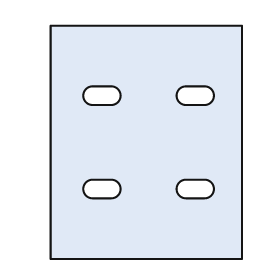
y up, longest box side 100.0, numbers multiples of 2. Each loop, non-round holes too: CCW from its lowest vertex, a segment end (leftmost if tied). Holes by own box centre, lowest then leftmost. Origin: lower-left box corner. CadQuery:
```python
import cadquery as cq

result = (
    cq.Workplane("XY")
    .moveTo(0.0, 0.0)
    .lineTo(82.0, 0.0)
    .lineTo(82.0, 100.0)
    .lineTo(0.0, 100.0)
    .close()
    .moveTo(18.0, 26.0)
    .lineTo(26.0, 26.0)
    .threePointArc((30.0, 30.0), (26.0, 34.0))
    .lineTo(18.0, 34.0)
    .threePointArc((14.0, 30.0), (18.0, 26.0))
    .close()
    .moveTo(58.0, 26.0)
    .lineTo(66.0, 26.0)
    .threePointArc((70.0, 30.0), (66.0, 34.0))
    .lineTo(58.0, 34.0)
    .threePointArc((54.0, 30.0), (58.0, 26.0))
    .close()
    .moveTo(18.0, 66.0)
    .lineTo(26.0, 66.0)
    .threePointArc((30.0, 70.0), (26.0, 74.0))
    .lineTo(18.0, 74.0)
    .threePointArc((14.0, 70.0), (18.0, 66.0))
    .close()
    .moveTo(58.0, 66.0)
    .lineTo(66.0, 66.0)
    .threePointArc((70.0, 70.0), (66.0, 74.0))
    .lineTo(58.0, 74.0)
    .threePointArc((54.0, 70.0), (58.0, 66.0))
    .close()
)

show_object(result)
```